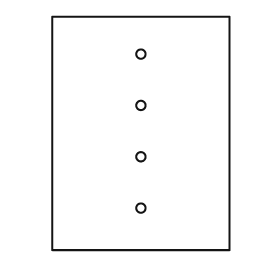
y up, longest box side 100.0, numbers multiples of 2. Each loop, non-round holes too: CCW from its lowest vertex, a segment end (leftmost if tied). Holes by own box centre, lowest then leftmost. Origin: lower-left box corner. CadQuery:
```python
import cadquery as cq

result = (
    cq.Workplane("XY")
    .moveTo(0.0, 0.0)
    .lineTo(76.0, 0.0)
    .lineTo(76.0, 100.0)
    .lineTo(0.0, 100.0)
    .close()
    .moveTo(38.0, 18.0)
    .circle(2.0)
    .moveTo(38.0, 40.0)
    .circle(2.0)
    .moveTo(38.0, 62.0)
    .circle(2.0)
    .moveTo(38.0, 84.0)
    .circle(2.0)
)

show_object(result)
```